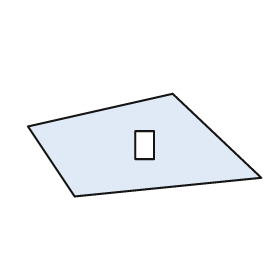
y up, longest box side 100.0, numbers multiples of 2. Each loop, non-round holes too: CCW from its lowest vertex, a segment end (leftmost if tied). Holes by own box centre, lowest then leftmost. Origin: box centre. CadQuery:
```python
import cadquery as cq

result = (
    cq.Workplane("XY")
    .moveTo(-30.0, -22.0)
    .lineTo(50.0, -14.0)
    .lineTo(12.0, 22.0)
    .lineTo(-50.0, 8.0)
    .close()
    .moveTo(-4.0, -6.0)
    .lineTo(4.0, -6.0)
    .lineTo(4.0, 6.0)
    .lineTo(-4.0, 6.0)
    .close()
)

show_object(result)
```